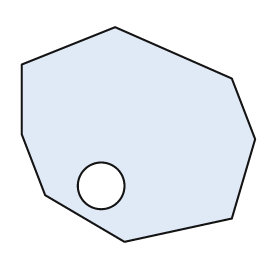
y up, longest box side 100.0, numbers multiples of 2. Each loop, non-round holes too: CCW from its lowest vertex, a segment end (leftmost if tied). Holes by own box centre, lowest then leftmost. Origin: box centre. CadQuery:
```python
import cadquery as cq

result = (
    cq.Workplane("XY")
    .moveTo(-6.0, -46.0)
    .lineTo(40.0, -36.0)
    .lineTo(50.0, -2.0)
    .lineTo(40.0, 24.0)
    .lineTo(-10.0, 46.0)
    .lineTo(-50.0, 30.0)
    .lineTo(-50.0, 0.0)
    .lineTo(-40.0, -26.0)
    .close()
    .moveTo(-16.0, -22.0)
    .circle(10.0)
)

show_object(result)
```